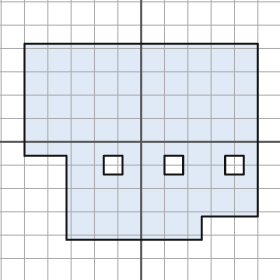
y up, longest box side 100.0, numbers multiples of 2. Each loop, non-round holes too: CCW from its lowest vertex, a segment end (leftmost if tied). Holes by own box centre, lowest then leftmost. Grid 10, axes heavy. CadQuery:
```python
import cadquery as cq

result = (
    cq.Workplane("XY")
    .moveTo(-32.0, -42.0)
    .lineTo(26.0, -42.0)
    .lineTo(26.0, -32.0)
    .lineTo(50.0, -32.0)
    .lineTo(50.0, 42.0)
    .lineTo(-50.0, 42.0)
    .lineTo(-50.0, -6.0)
    .lineTo(-32.0, -6.0)
    .close()
    .moveTo(-16.0, -14.0)
    .lineTo(-8.0, -14.0)
    .lineTo(-8.0, -6.0)
    .lineTo(-16.0, -6.0)
    .close()
    .moveTo(10.0, -14.0)
    .lineTo(18.0, -14.0)
    .lineTo(18.0, -6.0)
    .lineTo(10.0, -6.0)
    .close()
    .moveTo(36.0, -14.0)
    .lineTo(44.0, -14.0)
    .lineTo(44.0, -6.0)
    .lineTo(36.0, -6.0)
    .close()
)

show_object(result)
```